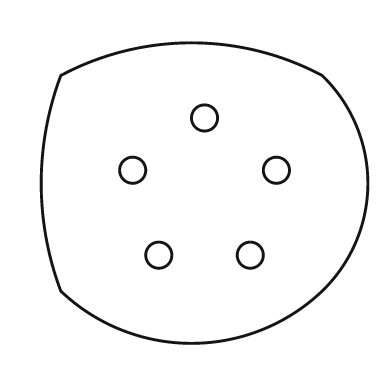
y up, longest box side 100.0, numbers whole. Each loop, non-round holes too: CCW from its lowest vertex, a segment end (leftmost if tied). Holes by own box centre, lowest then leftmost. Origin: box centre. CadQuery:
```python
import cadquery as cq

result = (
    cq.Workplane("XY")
    .moveTo(-44.0, -30.0)
    .threePointArc((-4.0, -46.0), (36.0, -30.0))
    .threePointArc((50.0, 3.0), (36.0, 36.0))
    .threePointArc((-4.0, 46.0), (-44.0, 36.0))
    .threePointArc((-50.0, 3.0), (-44.0, -30.0))
    .close()
    .moveTo(-14.0, -19.0)
    .circle(4.0)
    .moveTo(14.0, -19.0)
    .circle(4.0)
    .moveTo(-22.0, 7.0)
    .circle(4.0)
    .moveTo(22.0, 7.0)
    .circle(4.0)
    .moveTo(0.0, 23.0)
    .circle(4.0)
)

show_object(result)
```